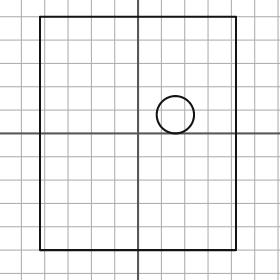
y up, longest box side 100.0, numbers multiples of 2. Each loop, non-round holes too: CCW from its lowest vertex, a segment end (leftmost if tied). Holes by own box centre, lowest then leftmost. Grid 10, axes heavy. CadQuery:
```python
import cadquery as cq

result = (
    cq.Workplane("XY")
    .moveTo(-42.0, -50.0)
    .lineTo(42.0, -50.0)
    .lineTo(42.0, 50.0)
    .lineTo(-42.0, 50.0)
    .close()
    .moveTo(16.0, 8.0)
    .circle(8.0)
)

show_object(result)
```